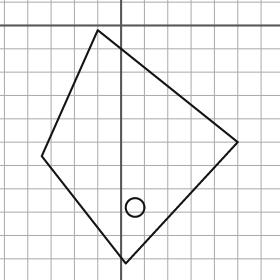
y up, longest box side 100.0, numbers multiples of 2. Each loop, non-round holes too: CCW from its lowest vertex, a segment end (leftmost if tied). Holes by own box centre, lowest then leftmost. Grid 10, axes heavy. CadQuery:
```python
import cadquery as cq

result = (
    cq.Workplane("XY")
    .moveTo(2.0, -102.0)
    .lineTo(50.0, -50.0)
    .lineTo(-10.0, -2.0)
    .lineTo(-34.0, -56.0)
    .close()
    .moveTo(6.0, -78.0)
    .circle(4.0)
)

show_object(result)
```